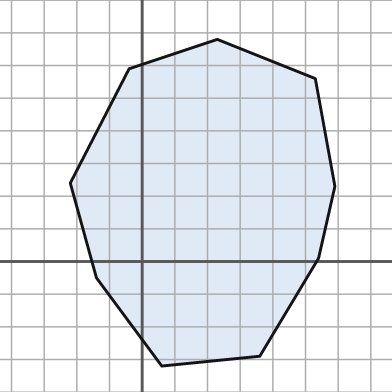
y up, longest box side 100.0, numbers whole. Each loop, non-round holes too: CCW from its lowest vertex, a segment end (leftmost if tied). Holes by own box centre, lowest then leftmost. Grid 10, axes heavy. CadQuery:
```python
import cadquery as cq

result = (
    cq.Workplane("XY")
    .moveTo(6.0, -32.0)
    .lineTo(36.0, -29.0)
    .lineTo(54.0, 1.0)
    .lineTo(59.0, 23.0)
    .lineTo(53.0, 56.0)
    .lineTo(23.0, 68.0)
    .lineTo(-4.0, 59.0)
    .lineTo(-22.0, 24.0)
    .lineTo(-14.0, -5.0)
    .close()
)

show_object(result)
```